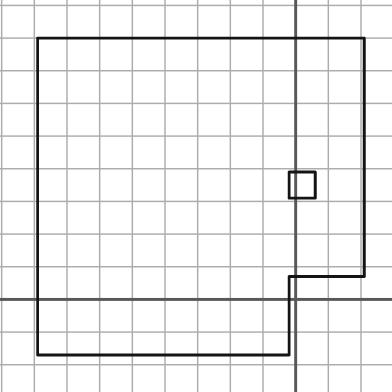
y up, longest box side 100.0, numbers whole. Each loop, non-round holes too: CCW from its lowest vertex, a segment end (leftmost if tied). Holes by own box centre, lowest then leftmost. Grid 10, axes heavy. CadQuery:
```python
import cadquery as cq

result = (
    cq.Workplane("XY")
    .moveTo(-79.0, -17.0)
    .lineTo(-2.0, -17.0)
    .lineTo(-2.0, 7.0)
    .lineTo(21.0, 7.0)
    .lineTo(21.0, 80.0)
    .lineTo(-79.0, 80.0)
    .close()
    .moveTo(-2.0, 31.0)
    .lineTo(6.0, 31.0)
    .lineTo(6.0, 39.0)
    .lineTo(-2.0, 39.0)
    .close()
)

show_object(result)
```